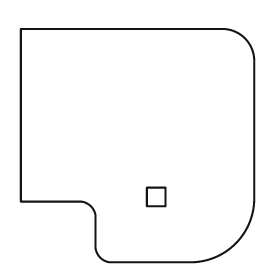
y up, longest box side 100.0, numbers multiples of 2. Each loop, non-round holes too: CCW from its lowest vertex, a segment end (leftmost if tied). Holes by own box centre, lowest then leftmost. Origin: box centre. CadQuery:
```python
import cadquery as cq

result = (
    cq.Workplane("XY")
    .moveTo(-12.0, -50.0)
    .lineTo(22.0, -50.0)
    .threePointArc((42.0, -42.0), (50.0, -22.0))
    .lineTo(50.0, 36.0)
    .threePointArc((46.0, 46.0), (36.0, 50.0))
    .lineTo(-50.0, 50.0)
    .lineTo(-50.0, -24.0)
    .lineTo(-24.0, -24.0)
    .threePointArc((-20.0, -26.0), (-18.0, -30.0))
    .lineTo(-18.0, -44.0)
    .threePointArc((-16.0, -48.0), (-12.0, -50.0))
    .close()
    .moveTo(4.0, -26.0)
    .lineTo(12.0, -26.0)
    .lineTo(12.0, -18.0)
    .lineTo(4.0, -18.0)
    .close()
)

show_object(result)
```